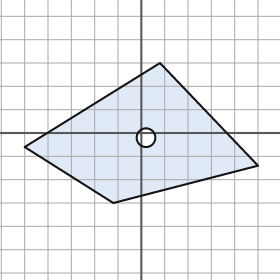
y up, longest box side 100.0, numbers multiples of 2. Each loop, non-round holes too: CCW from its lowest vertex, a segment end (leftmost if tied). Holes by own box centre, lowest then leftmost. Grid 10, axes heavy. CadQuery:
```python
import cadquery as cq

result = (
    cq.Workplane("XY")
    .moveTo(-12.0, -30.0)
    .lineTo(50.0, -14.0)
    .lineTo(8.0, 30.0)
    .lineTo(-50.0, -6.0)
    .close()
    .moveTo(2.0, -2.0)
    .circle(4.0)
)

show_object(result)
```